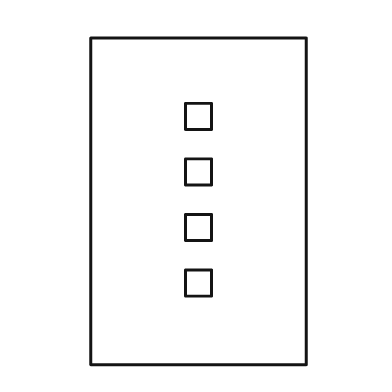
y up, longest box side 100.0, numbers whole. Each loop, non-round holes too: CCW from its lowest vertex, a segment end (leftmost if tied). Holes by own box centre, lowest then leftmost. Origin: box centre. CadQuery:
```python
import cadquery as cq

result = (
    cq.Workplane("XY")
    .moveTo(-33.0, -50.0)
    .lineTo(33.0, -50.0)
    .lineTo(33.0, 50.0)
    .lineTo(-33.0, 50.0)
    .close()
    .moveTo(-4.0, -29.0)
    .lineTo(4.0, -29.0)
    .lineTo(4.0, -21.0)
    .lineTo(-4.0, -21.0)
    .close()
    .moveTo(-4.0, -12.0)
    .lineTo(4.0, -12.0)
    .lineTo(4.0, -4.0)
    .lineTo(-4.0, -4.0)
    .close()
    .moveTo(-4.0, 5.0)
    .lineTo(4.0, 5.0)
    .lineTo(4.0, 13.0)
    .lineTo(-4.0, 13.0)
    .close()
    .moveTo(-4.0, 22.0)
    .lineTo(4.0, 22.0)
    .lineTo(4.0, 30.0)
    .lineTo(-4.0, 30.0)
    .close()
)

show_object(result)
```